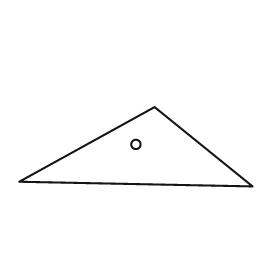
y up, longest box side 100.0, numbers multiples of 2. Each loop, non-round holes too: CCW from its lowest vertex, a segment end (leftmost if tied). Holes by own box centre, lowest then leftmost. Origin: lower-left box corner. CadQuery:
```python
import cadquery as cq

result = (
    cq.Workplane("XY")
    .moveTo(100.0, 0.0)
    .lineTo(58.0, 34.0)
    .lineTo(0.0, 2.0)
    .close()
    .moveTo(50.0, 18.0)
    .circle(2.0)
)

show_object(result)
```